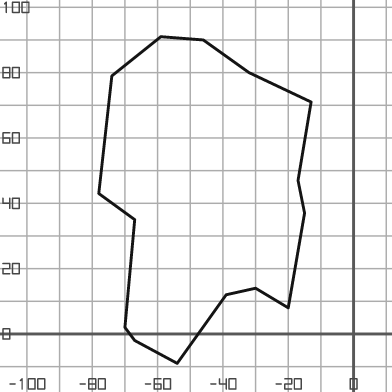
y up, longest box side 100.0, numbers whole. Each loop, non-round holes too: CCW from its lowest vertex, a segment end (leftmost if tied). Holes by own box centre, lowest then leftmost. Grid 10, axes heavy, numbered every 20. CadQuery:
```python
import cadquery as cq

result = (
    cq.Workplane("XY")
    .moveTo(-54.0, -9.0)
    .lineTo(-39.0, 12.0)
    .lineTo(-30.0, 14.0)
    .lineTo(-20.0, 8.0)
    .lineTo(-15.0, 37.0)
    .lineTo(-17.0, 47.0)
    .lineTo(-13.0, 71.0)
    .lineTo(-32.0, 80.0)
    .lineTo(-46.0, 90.0)
    .lineTo(-59.0, 91.0)
    .lineTo(-74.0, 79.0)
    .lineTo(-78.0, 43.0)
    .lineTo(-67.0, 35.0)
    .lineTo(-70.0, 2.0)
    .lineTo(-67.0, -2.0)
    .close()
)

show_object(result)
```